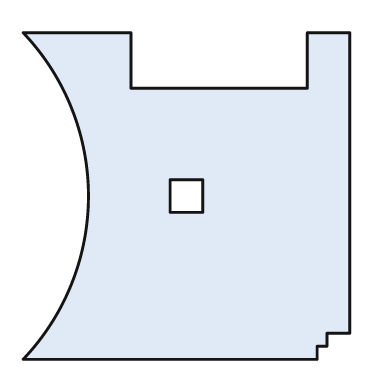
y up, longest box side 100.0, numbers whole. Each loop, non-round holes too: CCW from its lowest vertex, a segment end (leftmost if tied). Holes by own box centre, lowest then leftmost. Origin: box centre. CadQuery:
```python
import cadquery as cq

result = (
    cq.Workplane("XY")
    .moveTo(-50.0, -50.0)
    .lineTo(40.0, -50.0)
    .lineTo(40.0, -46.0)
    .lineTo(43.0, -46.0)
    .lineTo(43.0, -42.0)
    .lineTo(50.0, -42.0)
    .lineTo(50.0, 50.0)
    .lineTo(37.0, 50.0)
    .lineTo(37.0, 33.0)
    .lineTo(-17.0, 33.0)
    .lineTo(-17.0, 50.0)
    .lineTo(-50.0, 50.0)
    .threePointArc((-30.0, 0.0), (-50.0, -50.0))
    .close()
    .moveTo(-5.0, -5.0)
    .lineTo(5.0, -5.0)
    .lineTo(5.0, 5.0)
    .lineTo(-5.0, 5.0)
    .close()
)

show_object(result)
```